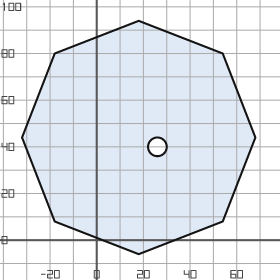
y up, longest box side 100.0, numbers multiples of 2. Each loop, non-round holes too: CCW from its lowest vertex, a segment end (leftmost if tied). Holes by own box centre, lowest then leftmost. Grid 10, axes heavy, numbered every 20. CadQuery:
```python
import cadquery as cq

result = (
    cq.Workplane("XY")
    .moveTo(18.0, -6.0)
    .lineTo(54.0, 8.0)
    .lineTo(68.0, 44.0)
    .lineTo(54.0, 80.0)
    .lineTo(18.0, 94.0)
    .lineTo(-18.0, 80.0)
    .lineTo(-32.0, 44.0)
    .lineTo(-18.0, 8.0)
    .close()
    .moveTo(26.0, 40.0)
    .circle(4.0)
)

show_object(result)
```